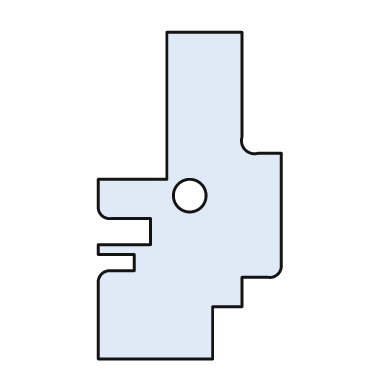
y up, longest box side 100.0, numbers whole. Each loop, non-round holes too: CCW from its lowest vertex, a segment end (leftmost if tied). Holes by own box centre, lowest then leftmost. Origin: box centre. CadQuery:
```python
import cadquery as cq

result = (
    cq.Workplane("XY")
    .moveTo(-28.0, -50.0)
    .lineTo(7.0, -50.0)
    .lineTo(7.0, -34.0)
    .lineTo(16.0, -34.0)
    .lineTo(16.0, -25.0)
    .lineTo(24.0, -25.0)
    .threePointArc((27.0, -24.0), (28.0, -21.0))
    .lineTo(28.0, 13.0)
    .lineTo(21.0, 13.0)
    .threePointArc((17.0, 14.0), (16.0, 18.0))
    .lineTo(16.0, 50.0)
    .lineTo(-7.0, 50.0)
    .lineTo(-7.0, 5.0)
    .lineTo(-28.0, 5.0)
    .lineTo(-28.0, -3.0)
    .threePointArc((-27.0, -6.0), (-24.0, -7.0))
    .lineTo(-12.0, -7.0)
    .lineTo(-12.0, -15.0)
    .lineTo(-28.0, -15.0)
    .lineTo(-28.0, -18.0)
    .lineTo(-17.0, -18.0)
    .lineTo(-17.0, -23.0)
    .lineTo(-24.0, -23.0)
    .threePointArc((-27.0, -24.0), (-28.0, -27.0))
    .close()
    .moveTo(0.0, 0.0)
    .circle(5.0)
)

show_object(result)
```